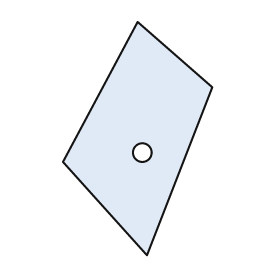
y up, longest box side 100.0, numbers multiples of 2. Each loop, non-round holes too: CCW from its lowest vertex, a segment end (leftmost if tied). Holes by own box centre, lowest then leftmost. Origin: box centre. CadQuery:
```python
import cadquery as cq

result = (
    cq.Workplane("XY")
    .moveTo(4.0, -50.0)
    .lineTo(32.0, 22.0)
    .lineTo(0.0, 50.0)
    .lineTo(-32.0, -10.0)
    .close()
    .moveTo(2.0, -6.0)
    .circle(4.0)
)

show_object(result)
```